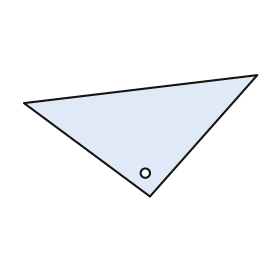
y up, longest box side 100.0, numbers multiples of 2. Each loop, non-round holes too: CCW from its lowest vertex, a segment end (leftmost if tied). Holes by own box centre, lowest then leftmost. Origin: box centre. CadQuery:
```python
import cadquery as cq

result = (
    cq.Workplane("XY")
    .moveTo(4.0, -26.0)
    .lineTo(50.0, 26.0)
    .lineTo(-50.0, 14.0)
    .close()
    .moveTo(2.0, -16.0)
    .circle(2.0)
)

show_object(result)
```